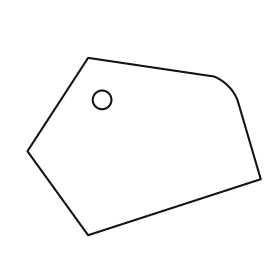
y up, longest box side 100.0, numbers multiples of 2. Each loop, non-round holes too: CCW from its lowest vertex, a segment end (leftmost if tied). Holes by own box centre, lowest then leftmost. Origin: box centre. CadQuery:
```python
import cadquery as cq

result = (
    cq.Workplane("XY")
    .moveTo(-24.0, -38.0)
    .lineTo(50.0, -14.0)
    .lineTo(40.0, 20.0)
    .threePointArc((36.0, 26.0), (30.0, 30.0))
    .lineTo(-24.0, 38.0)
    .lineTo(-50.0, -2.0)
    .close()
    .moveTo(-18.0, 20.0)
    .circle(4.0)
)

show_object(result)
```